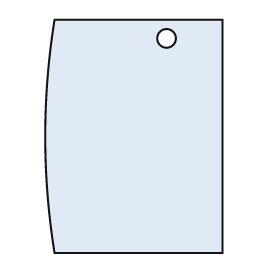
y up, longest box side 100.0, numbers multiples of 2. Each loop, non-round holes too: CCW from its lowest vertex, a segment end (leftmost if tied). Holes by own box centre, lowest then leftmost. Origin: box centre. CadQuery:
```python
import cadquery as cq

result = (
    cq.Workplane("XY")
    .moveTo(-34.0, -50.0)
    .lineTo(38.0, -50.0)
    .lineTo(38.0, 50.0)
    .lineTo(-34.0, 50.0)
    .threePointArc((-38.0, 0.0), (-34.0, -50.0))
    .close()
    .moveTo(14.0, 42.0)
    .circle(4.0)
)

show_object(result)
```